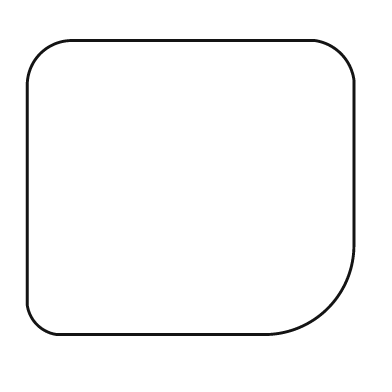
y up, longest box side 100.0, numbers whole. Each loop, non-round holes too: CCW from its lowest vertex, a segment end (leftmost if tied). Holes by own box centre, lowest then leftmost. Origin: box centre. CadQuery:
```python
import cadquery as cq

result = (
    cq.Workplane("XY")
    .moveTo(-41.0, -45.0)
    .lineTo(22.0, -45.0)
    .threePointArc((42.0, -37.0), (50.0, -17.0))
    .lineTo(50.0, 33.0)
    .threePointArc((46.0, 41.0), (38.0, 45.0))
    .lineTo(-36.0, 45.0)
    .threePointArc((-46.0, 41.0), (-50.0, 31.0))
    .lineTo(-50.0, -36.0)
    .threePointArc((-47.0, -42.0), (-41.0, -45.0))
    .close()
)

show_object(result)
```